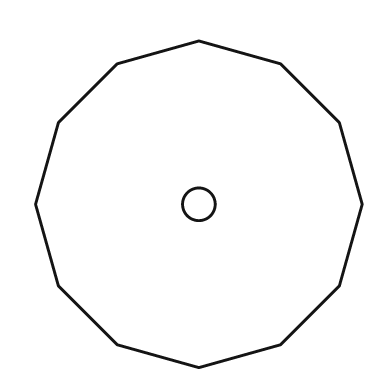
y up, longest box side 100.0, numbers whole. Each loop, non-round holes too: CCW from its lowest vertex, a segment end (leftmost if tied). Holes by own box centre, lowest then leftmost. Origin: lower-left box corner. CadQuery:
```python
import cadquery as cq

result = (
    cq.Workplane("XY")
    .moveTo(50.0, 0.0)
    .lineTo(75.0, 7.0)
    .lineTo(93.0, 25.0)
    .lineTo(100.0, 50.0)
    .lineTo(93.0, 75.0)
    .lineTo(75.0, 93.0)
    .lineTo(50.0, 100.0)
    .lineTo(25.0, 93.0)
    .lineTo(7.0, 75.0)
    .lineTo(0.0, 50.0)
    .lineTo(7.0, 25.0)
    .lineTo(25.0, 7.0)
    .close()
    .moveTo(50.0, 50.0)
    .circle(5.0)
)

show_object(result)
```